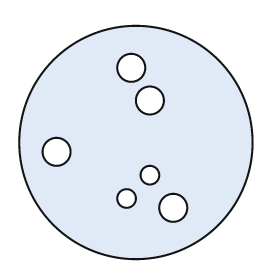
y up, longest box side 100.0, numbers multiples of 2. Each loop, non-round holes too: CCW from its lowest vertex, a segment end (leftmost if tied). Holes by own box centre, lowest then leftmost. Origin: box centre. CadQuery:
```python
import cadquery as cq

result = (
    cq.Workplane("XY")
    .moveTo(0.0, 0.0)
    .circle(50.0)
    .moveTo(16.0, -28.0)
    .circle(6.0)
    .moveTo(-4.0, -24.0)
    .circle(4.0)
    .moveTo(6.0, -14.0)
    .circle(4.0)
    .moveTo(-34.0, -4.0)
    .circle(6.0)
    .moveTo(6.0, 18.0)
    .circle(6.0)
    .moveTo(-2.0, 32.0)
    .circle(6.0)
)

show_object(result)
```